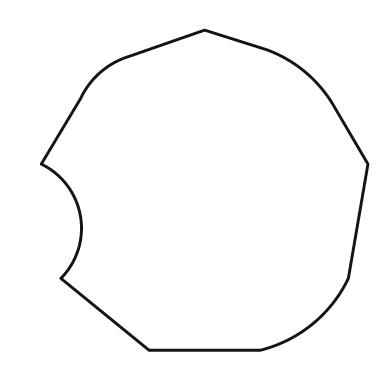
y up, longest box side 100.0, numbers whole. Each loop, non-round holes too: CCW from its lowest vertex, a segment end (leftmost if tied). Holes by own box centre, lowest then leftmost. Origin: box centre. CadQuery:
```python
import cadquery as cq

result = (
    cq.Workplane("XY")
    .moveTo(-17.0, -49.0)
    .lineTo(17.0, -49.0)
    .threePointArc((33.0, -41.0), (44.0, -27.0))
    .lineTo(50.0, 8.0)
    .lineTo(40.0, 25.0)
    .threePointArc((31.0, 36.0), (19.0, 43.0))
    .lineTo(0.0, 49.0)
    .lineTo(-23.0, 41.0)
    .threePointArc((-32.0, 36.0), (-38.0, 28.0))
    .lineTo(-50.0, 8.0)
    .threePointArc((-38.0, -8.0), (-44.0, -27.0))
    .close()
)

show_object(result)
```